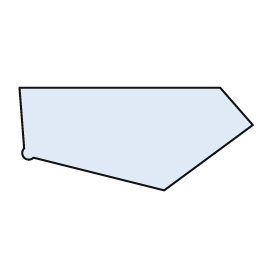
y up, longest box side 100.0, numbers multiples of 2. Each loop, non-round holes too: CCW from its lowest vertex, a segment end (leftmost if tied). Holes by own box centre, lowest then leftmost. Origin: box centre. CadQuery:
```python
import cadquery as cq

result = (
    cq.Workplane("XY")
    .moveTo(12.0, -22.0)
    .lineTo(50.0, 6.0)
    .lineTo(36.0, 22.0)
    .lineTo(-50.0, 22.0)
    .lineTo(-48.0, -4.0)
    .threePointArc((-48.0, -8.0), (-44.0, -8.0))
    .close()
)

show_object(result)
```